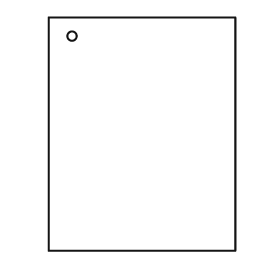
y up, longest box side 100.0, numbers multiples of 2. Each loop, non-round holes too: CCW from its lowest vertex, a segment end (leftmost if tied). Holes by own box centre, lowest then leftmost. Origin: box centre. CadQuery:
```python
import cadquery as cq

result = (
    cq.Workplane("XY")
    .moveTo(-40.0, -50.0)
    .lineTo(40.0, -50.0)
    .lineTo(40.0, 50.0)
    .lineTo(-40.0, 50.0)
    .close()
    .moveTo(-30.0, 42.0)
    .circle(2.0)
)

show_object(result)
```